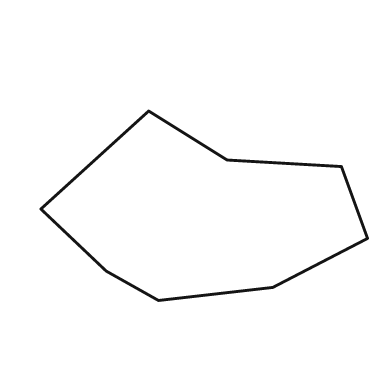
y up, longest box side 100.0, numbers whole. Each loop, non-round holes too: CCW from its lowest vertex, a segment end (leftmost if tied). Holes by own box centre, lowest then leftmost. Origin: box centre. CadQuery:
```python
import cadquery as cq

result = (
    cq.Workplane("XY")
    .moveTo(-14.0, -29.0)
    .lineTo(21.0, -25.0)
    .lineTo(50.0, -10.0)
    .lineTo(42.0, 12.0)
    .lineTo(7.0, 14.0)
    .lineTo(-17.0, 29.0)
    .lineTo(-50.0, -1.0)
    .lineTo(-30.0, -20.0)
    .close()
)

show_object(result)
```